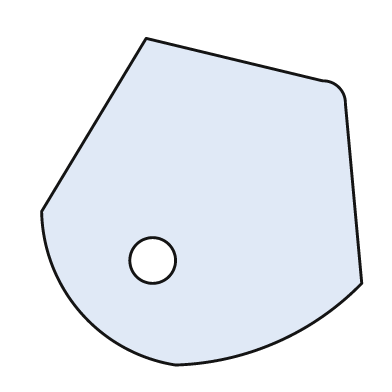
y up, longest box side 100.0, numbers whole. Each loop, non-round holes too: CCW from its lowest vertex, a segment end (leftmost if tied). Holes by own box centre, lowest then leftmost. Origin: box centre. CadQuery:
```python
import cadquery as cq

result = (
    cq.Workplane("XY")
    .moveTo(-8.0, -50.0)
    .threePointArc((23.0, -43.0), (49.0, -25.0))
    .lineTo(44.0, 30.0)
    .threePointArc((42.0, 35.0), (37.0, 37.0))
    .lineTo(-17.0, 50.0)
    .lineTo(-49.0, -3.0)
    .threePointArc((-37.0, -34.0), (-8.0, -50.0))
    .close()
    .moveTo(-15.0, -18.0)
    .circle(7.0)
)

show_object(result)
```